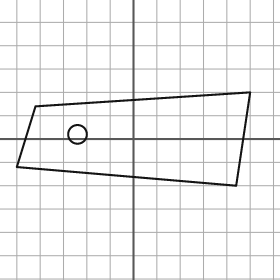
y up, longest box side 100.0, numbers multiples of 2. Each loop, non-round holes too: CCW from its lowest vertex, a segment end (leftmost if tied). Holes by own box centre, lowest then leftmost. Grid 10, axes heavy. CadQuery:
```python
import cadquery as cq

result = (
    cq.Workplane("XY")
    .moveTo(44.0, -20.0)
    .lineTo(50.0, 20.0)
    .lineTo(-42.0, 14.0)
    .lineTo(-50.0, -12.0)
    .close()
    .moveTo(-24.0, 2.0)
    .circle(4.0)
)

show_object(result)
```